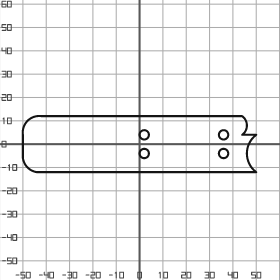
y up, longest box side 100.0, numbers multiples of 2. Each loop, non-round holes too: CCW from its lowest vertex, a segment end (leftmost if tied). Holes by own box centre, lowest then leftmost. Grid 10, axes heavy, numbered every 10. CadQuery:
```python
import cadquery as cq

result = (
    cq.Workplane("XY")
    .moveTo(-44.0, -12.0)
    .lineTo(50.0, -12.0)
    .threePointArc((46.0, -4.0), (50.0, 4.0))
    .lineTo(44.0, 4.0)
    .threePointArc((46.0, 8.0), (44.0, 12.0))
    .lineTo(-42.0, 12.0)
    .threePointArc((-48.0, 10.0), (-50.0, 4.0))
    .lineTo(-50.0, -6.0)
    .threePointArc((-48.0, -10.0), (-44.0, -12.0))
    .close()
    .moveTo(2.0, -4.0)
    .circle(2.0)
    .moveTo(36.0, -4.0)
    .circle(2.0)
    .moveTo(2.0, 4.0)
    .circle(2.0)
    .moveTo(36.0, 4.0)
    .circle(2.0)
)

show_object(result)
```